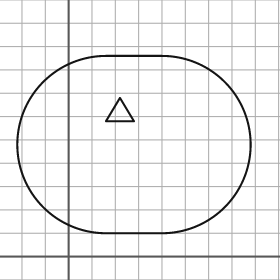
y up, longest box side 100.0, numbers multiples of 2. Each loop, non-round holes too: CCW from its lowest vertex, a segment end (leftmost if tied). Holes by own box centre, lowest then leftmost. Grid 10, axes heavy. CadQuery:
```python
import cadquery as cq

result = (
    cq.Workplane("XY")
    .moveTo(16.0, 10.0)
    .lineTo(40.0, 10.0)
    .threePointArc((78.0, 48.0), (40.0, 86.0))
    .lineTo(16.0, 86.0)
    .threePointArc((-22.0, 48.0), (16.0, 10.0))
    .close()
    .moveTo(16.0, 58.0)
    .lineTo(28.0, 58.0)
    .lineTo(22.0, 68.0)
    .close()
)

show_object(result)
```